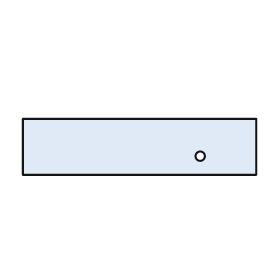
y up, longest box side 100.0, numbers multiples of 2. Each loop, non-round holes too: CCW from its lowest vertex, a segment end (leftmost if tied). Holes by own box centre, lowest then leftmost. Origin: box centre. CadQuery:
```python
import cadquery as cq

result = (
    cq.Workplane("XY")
    .moveTo(-50.0, -12.0)
    .lineTo(50.0, -12.0)
    .lineTo(50.0, 12.0)
    .lineTo(-50.0, 12.0)
    .close()
    .moveTo(26.0, -4.0)
    .circle(2.0)
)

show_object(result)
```